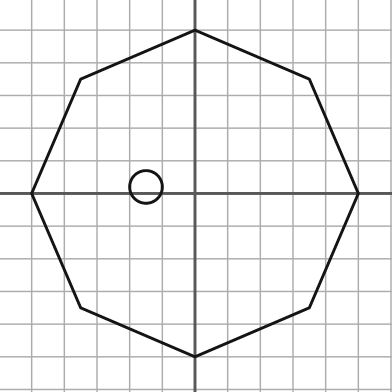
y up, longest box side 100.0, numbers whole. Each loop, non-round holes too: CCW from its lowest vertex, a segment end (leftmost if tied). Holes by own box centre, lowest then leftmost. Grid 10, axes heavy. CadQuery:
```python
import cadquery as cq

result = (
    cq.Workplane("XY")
    .moveTo(0.0, -50.0)
    .lineTo(35.0, -35.0)
    .lineTo(50.0, 0.0)
    .lineTo(35.0, 35.0)
    .lineTo(0.0, 50.0)
    .lineTo(-35.0, 35.0)
    .lineTo(-50.0, 0.0)
    .lineTo(-35.0, -35.0)
    .close()
    .moveTo(-15.0, 2.0)
    .circle(5.0)
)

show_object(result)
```